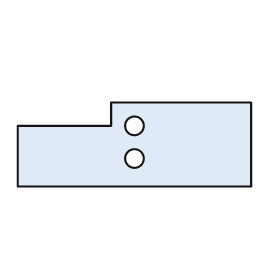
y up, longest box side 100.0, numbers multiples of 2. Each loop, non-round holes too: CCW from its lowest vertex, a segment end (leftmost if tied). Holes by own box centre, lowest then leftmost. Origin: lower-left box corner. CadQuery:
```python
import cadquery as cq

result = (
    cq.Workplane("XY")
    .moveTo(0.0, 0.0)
    .lineTo(100.0, 0.0)
    .lineTo(100.0, 36.0)
    .lineTo(40.0, 36.0)
    .lineTo(40.0, 26.0)
    .lineTo(0.0, 26.0)
    .close()
    .moveTo(50.0, 12.0)
    .circle(4.0)
    .moveTo(50.0, 26.0)
    .circle(4.0)
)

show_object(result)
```